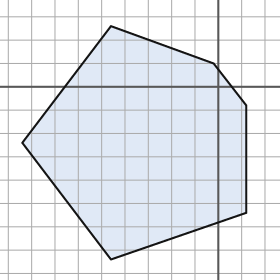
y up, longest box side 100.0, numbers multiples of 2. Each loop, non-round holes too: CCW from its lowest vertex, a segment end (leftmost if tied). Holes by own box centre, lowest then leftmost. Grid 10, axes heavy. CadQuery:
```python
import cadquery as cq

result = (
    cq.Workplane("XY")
    .moveTo(-46.0, -74.0)
    .lineTo(12.0, -54.0)
    .lineTo(12.0, -8.0)
    .lineTo(-2.0, 10.0)
    .lineTo(-46.0, 26.0)
    .lineTo(-84.0, -24.0)
    .close()
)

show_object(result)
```